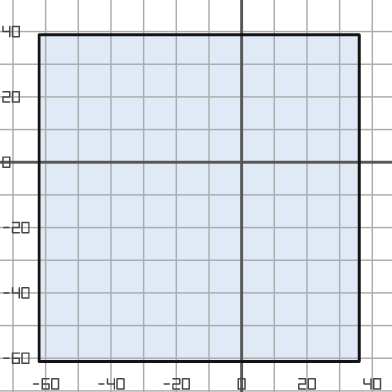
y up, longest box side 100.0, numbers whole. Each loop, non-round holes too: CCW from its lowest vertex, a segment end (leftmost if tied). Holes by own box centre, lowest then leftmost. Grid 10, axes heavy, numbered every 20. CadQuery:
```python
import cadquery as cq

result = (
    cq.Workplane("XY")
    .moveTo(-62.0, -61.0)
    .lineTo(36.0, -61.0)
    .lineTo(36.0, 39.0)
    .lineTo(-62.0, 39.0)
    .close()
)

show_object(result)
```